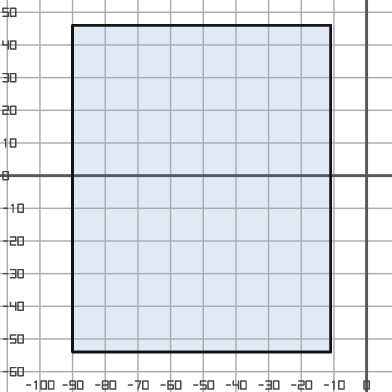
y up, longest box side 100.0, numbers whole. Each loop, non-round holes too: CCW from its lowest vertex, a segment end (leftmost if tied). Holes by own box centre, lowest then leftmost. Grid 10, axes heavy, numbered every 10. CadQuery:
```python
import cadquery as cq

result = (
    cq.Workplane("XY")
    .moveTo(-90.0, -54.0)
    .lineTo(-11.0, -54.0)
    .lineTo(-11.0, 46.0)
    .lineTo(-90.0, 46.0)
    .close()
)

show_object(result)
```